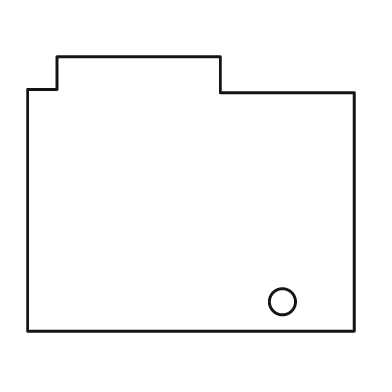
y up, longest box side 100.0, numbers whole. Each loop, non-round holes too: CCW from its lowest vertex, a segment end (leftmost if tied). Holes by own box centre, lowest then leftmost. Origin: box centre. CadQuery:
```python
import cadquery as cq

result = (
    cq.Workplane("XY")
    .moveTo(-50.0, -42.0)
    .lineTo(50.0, -42.0)
    .lineTo(50.0, 31.0)
    .lineTo(9.0, 31.0)
    .lineTo(9.0, 42.0)
    .lineTo(-41.0, 42.0)
    .lineTo(-41.0, 32.0)
    .lineTo(-50.0, 32.0)
    .close()
    .moveTo(28.0, -33.0)
    .circle(4.0)
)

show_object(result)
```